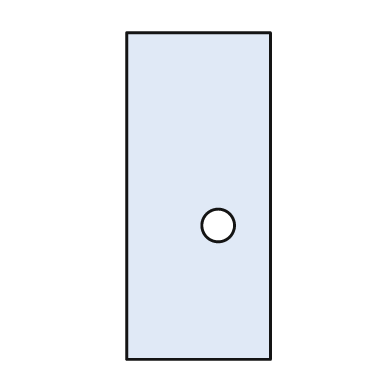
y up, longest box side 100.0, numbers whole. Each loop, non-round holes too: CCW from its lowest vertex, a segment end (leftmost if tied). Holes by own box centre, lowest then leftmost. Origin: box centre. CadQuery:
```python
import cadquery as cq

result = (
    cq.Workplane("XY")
    .moveTo(-22.0, -50.0)
    .lineTo(22.0, -50.0)
    .lineTo(22.0, 50.0)
    .lineTo(-22.0, 50.0)
    .close()
    .moveTo(6.0, -9.0)
    .circle(5.0)
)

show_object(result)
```